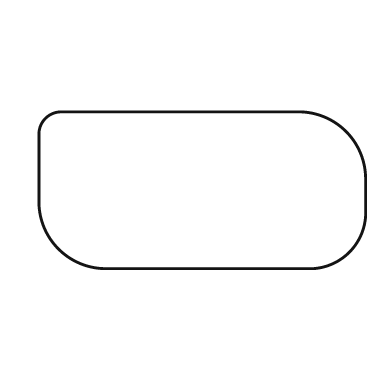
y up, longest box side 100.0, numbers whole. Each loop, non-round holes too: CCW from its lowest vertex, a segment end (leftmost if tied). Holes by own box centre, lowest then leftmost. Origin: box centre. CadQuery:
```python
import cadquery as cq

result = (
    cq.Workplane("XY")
    .moveTo(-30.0, -24.0)
    .lineTo(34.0, -24.0)
    .threePointArc((45.0, -19.0), (50.0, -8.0))
    .lineTo(50.0, 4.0)
    .threePointArc((44.0, 18.0), (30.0, 24.0))
    .lineTo(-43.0, 24.0)
    .threePointArc((-48.0, 22.0), (-50.0, 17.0))
    .lineTo(-50.0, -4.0)
    .threePointArc((-44.0, -18.0), (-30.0, -24.0))
    .close()
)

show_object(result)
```